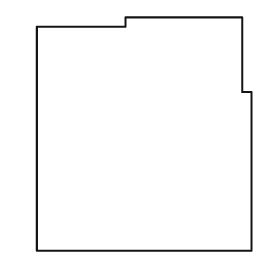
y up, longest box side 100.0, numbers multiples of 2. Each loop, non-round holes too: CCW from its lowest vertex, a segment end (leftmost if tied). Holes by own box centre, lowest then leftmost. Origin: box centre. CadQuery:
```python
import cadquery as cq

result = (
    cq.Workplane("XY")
    .moveTo(-46.0, -50.0)
    .lineTo(46.0, -50.0)
    .lineTo(46.0, 18.0)
    .lineTo(42.0, 18.0)
    .lineTo(42.0, 50.0)
    .lineTo(-8.0, 50.0)
    .lineTo(-8.0, 46.0)
    .lineTo(-46.0, 46.0)
    .close()
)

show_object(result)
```